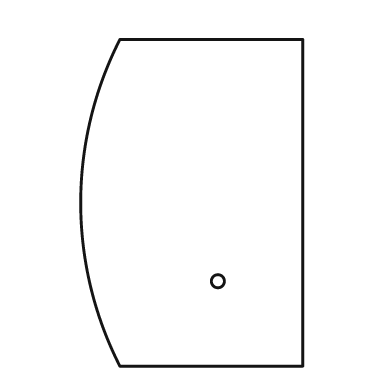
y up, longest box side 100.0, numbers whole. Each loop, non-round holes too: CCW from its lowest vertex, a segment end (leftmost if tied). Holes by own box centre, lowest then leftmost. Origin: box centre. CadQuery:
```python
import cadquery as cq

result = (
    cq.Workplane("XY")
    .moveTo(-22.0, -50.0)
    .lineTo(34.0, -50.0)
    .lineTo(34.0, 50.0)
    .lineTo(-22.0, 50.0)
    .threePointArc((-34.0, 0.0), (-22.0, -50.0))
    .close()
    .moveTo(8.0, -24.0)
    .circle(2.0)
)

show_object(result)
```